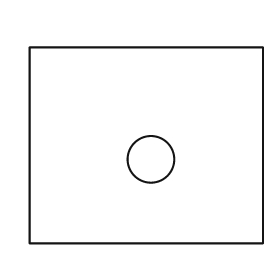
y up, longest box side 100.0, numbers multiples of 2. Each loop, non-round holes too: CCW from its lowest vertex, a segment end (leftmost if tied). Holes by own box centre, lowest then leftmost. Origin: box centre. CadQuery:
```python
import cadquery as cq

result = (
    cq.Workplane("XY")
    .moveTo(-50.0, -42.0)
    .lineTo(50.0, -42.0)
    .lineTo(50.0, 42.0)
    .lineTo(-50.0, 42.0)
    .close()
    .moveTo(2.0, -6.0)
    .circle(10.0)
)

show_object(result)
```